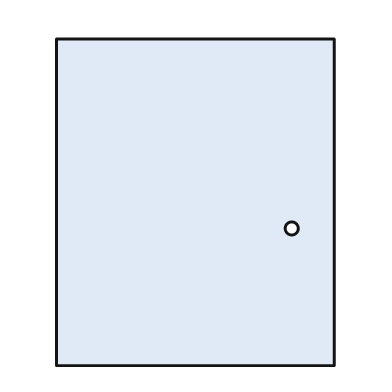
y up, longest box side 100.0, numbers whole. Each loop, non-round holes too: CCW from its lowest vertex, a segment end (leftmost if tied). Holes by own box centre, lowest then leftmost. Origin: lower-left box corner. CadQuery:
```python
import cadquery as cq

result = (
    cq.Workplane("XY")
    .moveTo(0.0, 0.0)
    .lineTo(85.0, 0.0)
    .lineTo(85.0, 100.0)
    .lineTo(0.0, 100.0)
    .close()
    .moveTo(72.0, 42.0)
    .circle(2.0)
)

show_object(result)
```